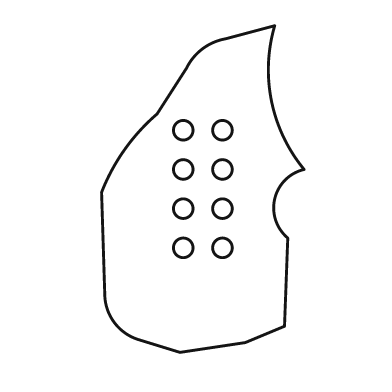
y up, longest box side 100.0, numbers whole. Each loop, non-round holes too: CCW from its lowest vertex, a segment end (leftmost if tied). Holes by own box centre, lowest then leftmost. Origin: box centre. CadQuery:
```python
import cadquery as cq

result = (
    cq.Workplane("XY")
    .moveTo(-7.0, -50.0)
    .lineTo(13.0, -47.0)
    .lineTo(25.0, -42.0)
    .lineTo(26.0, -15.0)
    .threePointArc((22.0, -3.0), (31.0, 6.0))
    .threePointArc((21.0, 27.0), (22.0, 50.0))
    .lineTo(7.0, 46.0)
    .threePointArc((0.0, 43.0), (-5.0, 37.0))
    .lineTo(-14.0, 23.0)
    .threePointArc((-24.0, 12.0), (-31.0, -1.0))
    .lineTo(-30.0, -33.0)
    .threePointArc((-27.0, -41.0), (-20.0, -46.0))
    .close()
    .moveTo(-6.0, -18.0)
    .circle(3.0)
    .moveTo(6.0, -18.0)
    .circle(3.0)
    .moveTo(-6.0, -6.0)
    .circle(3.0)
    .moveTo(6.0, -6.0)
    .circle(3.0)
    .moveTo(-6.0, 6.0)
    .circle(3.0)
    .moveTo(6.0, 6.0)
    .circle(3.0)
    .moveTo(-6.0, 18.0)
    .circle(3.0)
    .moveTo(6.0, 18.0)
    .circle(3.0)
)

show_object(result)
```